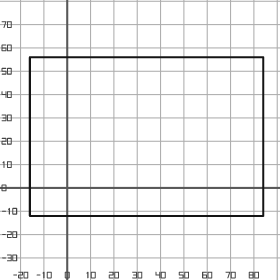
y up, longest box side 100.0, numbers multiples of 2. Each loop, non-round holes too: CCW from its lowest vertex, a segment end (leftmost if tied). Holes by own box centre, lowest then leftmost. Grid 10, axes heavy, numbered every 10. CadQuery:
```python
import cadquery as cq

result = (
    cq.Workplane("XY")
    .moveTo(-16.0, -12.0)
    .lineTo(84.0, -12.0)
    .lineTo(84.0, 56.0)
    .lineTo(-16.0, 56.0)
    .close()
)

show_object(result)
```